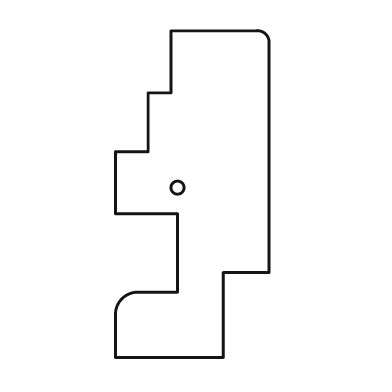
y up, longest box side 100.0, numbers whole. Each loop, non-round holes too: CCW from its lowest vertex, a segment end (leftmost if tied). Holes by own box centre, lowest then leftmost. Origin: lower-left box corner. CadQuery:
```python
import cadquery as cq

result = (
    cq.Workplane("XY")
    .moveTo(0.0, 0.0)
    .lineTo(33.0, 0.0)
    .lineTo(33.0, 26.0)
    .lineTo(47.0, 26.0)
    .lineTo(47.0, 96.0)
    .threePointArc((46.0, 99.0), (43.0, 100.0))
    .lineTo(17.0, 100.0)
    .lineTo(17.0, 81.0)
    .lineTo(10.0, 81.0)
    .lineTo(10.0, 63.0)
    .lineTo(0.0, 63.0)
    .lineTo(0.0, 44.0)
    .lineTo(19.0, 44.0)
    .lineTo(19.0, 20.0)
    .lineTo(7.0, 20.0)
    .threePointArc((2.0, 18.0), (0.0, 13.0))
    .close()
    .moveTo(19.0, 52.0)
    .circle(2.0)
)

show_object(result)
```